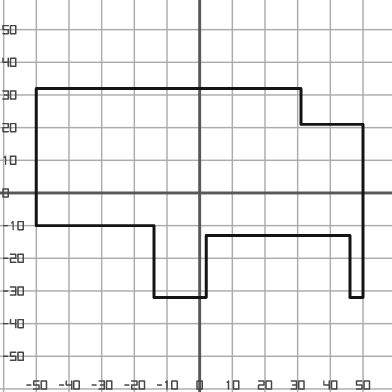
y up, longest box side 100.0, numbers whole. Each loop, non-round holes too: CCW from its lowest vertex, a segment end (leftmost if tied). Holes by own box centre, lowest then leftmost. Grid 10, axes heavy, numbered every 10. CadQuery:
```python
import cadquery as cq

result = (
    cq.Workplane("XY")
    .moveTo(-14.0, -32.0)
    .lineTo(2.0, -32.0)
    .lineTo(2.0, -13.0)
    .lineTo(46.0, -13.0)
    .lineTo(46.0, -32.0)
    .lineTo(50.0, -32.0)
    .lineTo(50.0, 21.0)
    .lineTo(31.0, 21.0)
    .lineTo(31.0, 32.0)
    .lineTo(-50.0, 32.0)
    .lineTo(-50.0, -10.0)
    .lineTo(-14.0, -10.0)
    .close()
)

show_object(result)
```